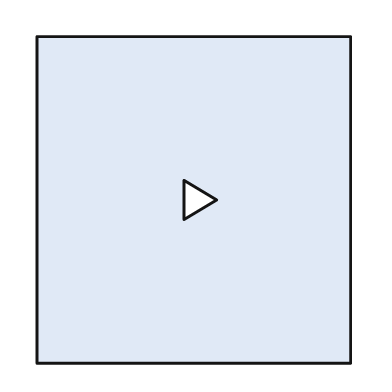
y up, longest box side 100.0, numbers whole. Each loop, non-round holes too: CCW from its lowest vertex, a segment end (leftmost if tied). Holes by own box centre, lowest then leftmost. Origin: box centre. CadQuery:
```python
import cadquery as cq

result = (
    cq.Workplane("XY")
    .moveTo(-48.0, -50.0)
    .lineTo(48.0, -50.0)
    .lineTo(48.0, 50.0)
    .lineTo(-48.0, 50.0)
    .close()
    .moveTo(-3.0, -6.0)
    .lineTo(7.0, 0.0)
    .lineTo(-3.0, 6.0)
    .close()
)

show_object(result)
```